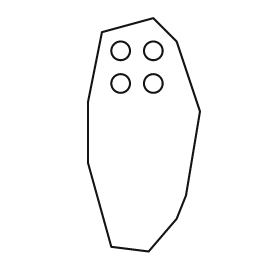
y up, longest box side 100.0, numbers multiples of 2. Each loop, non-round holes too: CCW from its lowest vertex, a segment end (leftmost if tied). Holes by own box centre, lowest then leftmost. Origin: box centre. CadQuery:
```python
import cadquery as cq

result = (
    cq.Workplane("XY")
    .moveTo(2.0, -50.0)
    .lineTo(14.0, -36.0)
    .lineTo(18.0, -26.0)
    .lineTo(24.0, 10.0)
    .lineTo(14.0, 40.0)
    .lineTo(4.0, 50.0)
    .lineTo(-18.0, 44.0)
    .lineTo(-24.0, 14.0)
    .lineTo(-24.0, -12.0)
    .lineTo(-14.0, -48.0)
    .close()
    .moveTo(-10.0, 22.0)
    .circle(4.0)
    .moveTo(4.0, 22.0)
    .circle(4.0)
    .moveTo(-10.0, 36.0)
    .circle(4.0)
    .moveTo(4.0, 36.0)
    .circle(4.0)
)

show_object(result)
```